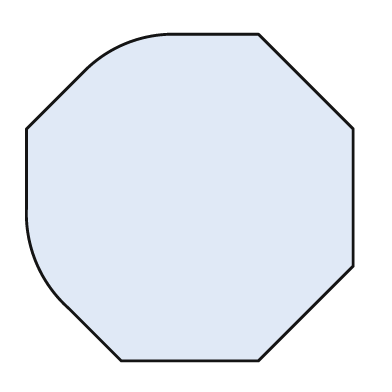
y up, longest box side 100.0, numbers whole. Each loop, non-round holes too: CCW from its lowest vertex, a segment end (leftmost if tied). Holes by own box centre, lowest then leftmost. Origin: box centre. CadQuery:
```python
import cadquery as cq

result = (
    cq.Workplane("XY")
    .moveTo(-21.0, -50.0)
    .lineTo(21.0, -50.0)
    .lineTo(50.0, -21.0)
    .lineTo(50.0, 21.0)
    .lineTo(21.0, 50.0)
    .lineTo(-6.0, 50.0)
    .threePointArc((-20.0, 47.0), (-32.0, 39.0))
    .lineTo(-50.0, 21.0)
    .lineTo(-50.0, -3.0)
    .threePointArc((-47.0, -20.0), (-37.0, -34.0))
    .close()
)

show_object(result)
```